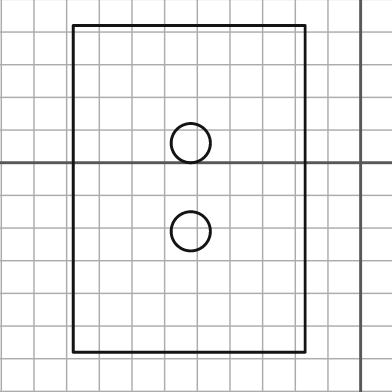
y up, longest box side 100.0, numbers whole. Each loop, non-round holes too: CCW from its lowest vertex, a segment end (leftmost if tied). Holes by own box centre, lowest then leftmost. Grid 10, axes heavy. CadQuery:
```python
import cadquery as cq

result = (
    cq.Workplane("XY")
    .moveTo(-88.0, -58.0)
    .lineTo(-17.0, -58.0)
    .lineTo(-17.0, 42.0)
    .lineTo(-88.0, 42.0)
    .close()
    .moveTo(-52.0, -21.0)
    .circle(6.0)
    .moveTo(-52.0, 6.0)
    .circle(6.0)
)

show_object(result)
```